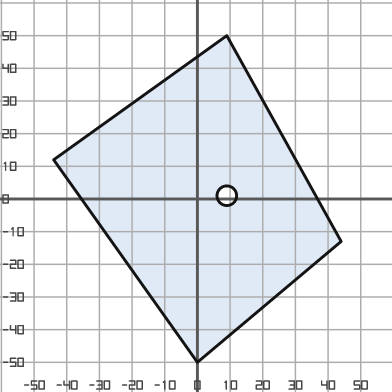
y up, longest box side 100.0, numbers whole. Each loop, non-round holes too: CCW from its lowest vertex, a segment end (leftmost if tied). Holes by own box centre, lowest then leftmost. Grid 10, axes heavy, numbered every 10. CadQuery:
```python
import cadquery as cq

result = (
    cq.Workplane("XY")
    .moveTo(0.0, -50.0)
    .lineTo(44.0, -13.0)
    .lineTo(9.0, 50.0)
    .lineTo(-44.0, 12.0)
    .close()
    .moveTo(9.0, 1.0)
    .circle(3.0)
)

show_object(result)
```